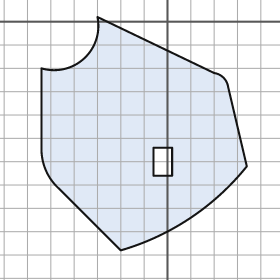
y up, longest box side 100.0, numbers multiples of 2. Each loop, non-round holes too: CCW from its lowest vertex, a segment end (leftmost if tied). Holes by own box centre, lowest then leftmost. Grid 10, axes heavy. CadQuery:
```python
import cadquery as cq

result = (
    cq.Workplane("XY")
    .moveTo(-20.0, -98.0)
    .threePointArc((10.0, -84.0), (34.0, -62.0))
    .lineTo(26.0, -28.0)
    .threePointArc((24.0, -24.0), (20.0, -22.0))
    .lineTo(-30.0, 2.0)
    .threePointArc((-36.0, -16.0), (-54.0, -20.0))
    .lineTo(-54.0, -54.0)
    .threePointArc((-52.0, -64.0), (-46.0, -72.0))
    .close()
    .moveTo(-6.0, -66.0)
    .lineTo(2.0, -66.0)
    .lineTo(2.0, -54.0)
    .lineTo(-6.0, -54.0)
    .close()
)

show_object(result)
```